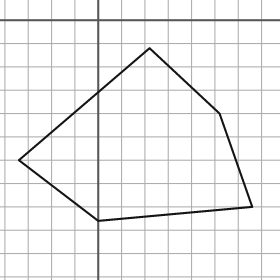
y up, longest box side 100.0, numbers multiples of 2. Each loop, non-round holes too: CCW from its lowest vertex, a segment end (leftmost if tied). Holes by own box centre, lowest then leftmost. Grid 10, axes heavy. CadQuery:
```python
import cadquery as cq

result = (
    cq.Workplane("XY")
    .moveTo(0.0, -86.0)
    .lineTo(66.0, -80.0)
    .lineTo(52.0, -40.0)
    .lineTo(22.0, -12.0)
    .lineTo(-34.0, -60.0)
    .close()
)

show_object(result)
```